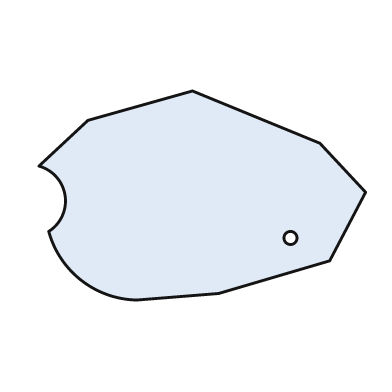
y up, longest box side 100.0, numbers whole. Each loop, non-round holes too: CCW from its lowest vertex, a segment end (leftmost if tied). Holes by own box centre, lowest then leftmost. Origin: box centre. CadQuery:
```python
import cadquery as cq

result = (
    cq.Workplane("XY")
    .moveTo(-20.0, -32.0)
    .lineTo(5.0, -30.0)
    .lineTo(39.0, -20.0)
    .lineTo(50.0, 1.0)
    .lineTo(36.0, 16.0)
    .lineTo(-3.0, 32.0)
    .lineTo(-35.0, 23.0)
    .lineTo(-50.0, 9.0)
    .threePointArc((-42.0, 0.0), (-47.0, -11.0))
    .threePointArc((-37.0, -26.0), (-20.0, -32.0))
    .close()
    .moveTo(27.0, -13.0)
    .circle(2.0)
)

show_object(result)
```